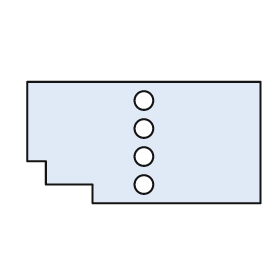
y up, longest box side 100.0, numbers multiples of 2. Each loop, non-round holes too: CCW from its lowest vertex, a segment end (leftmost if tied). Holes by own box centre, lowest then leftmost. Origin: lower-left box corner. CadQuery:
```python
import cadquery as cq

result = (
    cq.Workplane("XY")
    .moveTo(28.0, 0.0)
    .lineTo(100.0, 0.0)
    .lineTo(100.0, 52.0)
    .lineTo(0.0, 52.0)
    .lineTo(0.0, 18.0)
    .lineTo(8.0, 18.0)
    .lineTo(8.0, 8.0)
    .lineTo(28.0, 8.0)
    .close()
    .moveTo(50.0, 8.0)
    .circle(4.0)
    .moveTo(50.0, 20.0)
    .circle(4.0)
    .moveTo(50.0, 32.0)
    .circle(4.0)
    .moveTo(50.0, 44.0)
    .circle(4.0)
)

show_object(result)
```